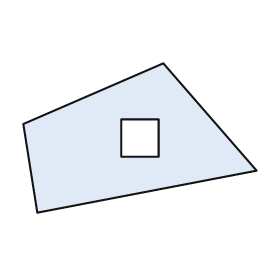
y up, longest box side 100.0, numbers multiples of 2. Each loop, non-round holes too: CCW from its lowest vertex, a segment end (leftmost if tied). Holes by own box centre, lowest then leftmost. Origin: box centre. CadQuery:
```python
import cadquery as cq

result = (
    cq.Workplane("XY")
    .moveTo(-44.0, -32.0)
    .lineTo(50.0, -14.0)
    .lineTo(10.0, 32.0)
    .lineTo(-50.0, 6.0)
    .close()
    .moveTo(-8.0, -8.0)
    .lineTo(8.0, -8.0)
    .lineTo(8.0, 8.0)
    .lineTo(-8.0, 8.0)
    .close()
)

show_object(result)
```